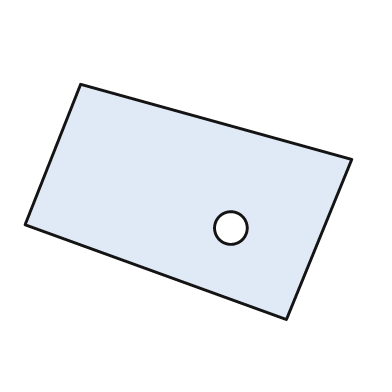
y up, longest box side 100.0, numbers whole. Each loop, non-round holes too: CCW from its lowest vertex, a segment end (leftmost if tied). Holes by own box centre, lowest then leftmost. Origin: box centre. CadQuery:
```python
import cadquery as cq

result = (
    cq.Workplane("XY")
    .moveTo(30.0, -36.0)
    .lineTo(50.0, 13.0)
    .lineTo(-33.0, 36.0)
    .lineTo(-50.0, -7.0)
    .close()
    .moveTo(13.0, -8.0)
    .circle(5.0)
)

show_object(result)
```